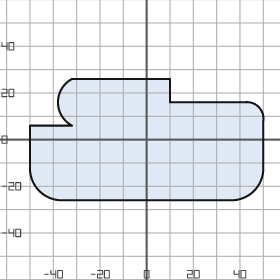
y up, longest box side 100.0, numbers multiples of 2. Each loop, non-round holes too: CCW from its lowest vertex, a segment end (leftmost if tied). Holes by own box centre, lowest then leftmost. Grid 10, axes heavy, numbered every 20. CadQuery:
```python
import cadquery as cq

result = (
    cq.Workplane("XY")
    .moveTo(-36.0, -26.0)
    .lineTo(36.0, -26.0)
    .threePointArc((46.0, -22.0), (50.0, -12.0))
    .lineTo(50.0, 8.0)
    .threePointArc((48.0, 14.0), (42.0, 16.0))
    .lineTo(10.0, 16.0)
    .lineTo(10.0, 26.0)
    .lineTo(-32.0, 26.0)
    .threePointArc((-38.0, 16.0), (-32.0, 6.0))
    .lineTo(-50.0, 6.0)
    .lineTo(-50.0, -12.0)
    .threePointArc((-46.0, -22.0), (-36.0, -26.0))
    .close()
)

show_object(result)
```